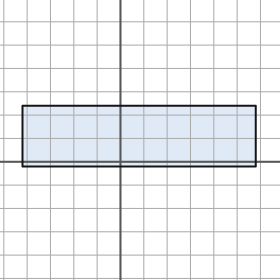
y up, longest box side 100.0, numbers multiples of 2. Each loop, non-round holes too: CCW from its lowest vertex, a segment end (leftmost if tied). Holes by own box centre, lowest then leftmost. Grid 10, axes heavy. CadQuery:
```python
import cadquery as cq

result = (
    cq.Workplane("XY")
    .moveTo(-42.0, -2.0)
    .lineTo(58.0, -2.0)
    .lineTo(58.0, 24.0)
    .lineTo(-42.0, 24.0)
    .close()
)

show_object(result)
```